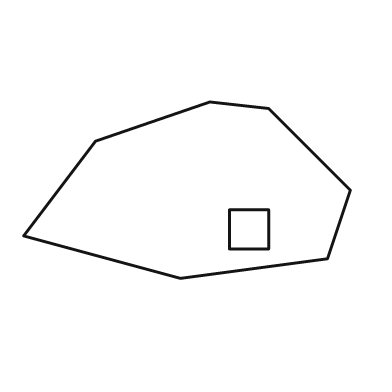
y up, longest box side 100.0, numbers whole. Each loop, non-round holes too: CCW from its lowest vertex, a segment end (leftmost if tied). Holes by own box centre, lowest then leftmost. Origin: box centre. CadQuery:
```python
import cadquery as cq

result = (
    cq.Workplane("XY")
    .moveTo(-2.0, -27.0)
    .lineTo(43.0, -21.0)
    .lineTo(50.0, 0.0)
    .lineTo(25.0, 25.0)
    .lineTo(7.0, 27.0)
    .lineTo(-28.0, 15.0)
    .lineTo(-50.0, -14.0)
    .close()
    .moveTo(13.0, -18.0)
    .lineTo(25.0, -18.0)
    .lineTo(25.0, -6.0)
    .lineTo(13.0, -6.0)
    .close()
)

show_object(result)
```